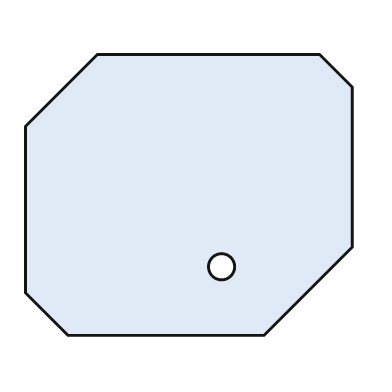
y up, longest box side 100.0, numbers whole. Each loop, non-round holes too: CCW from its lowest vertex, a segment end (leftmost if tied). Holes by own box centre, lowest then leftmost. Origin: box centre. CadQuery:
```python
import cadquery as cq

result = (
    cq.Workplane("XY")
    .moveTo(-37.0, -43.0)
    .lineTo(23.0, -43.0)
    .lineTo(50.0, -16.0)
    .lineTo(50.0, 33.0)
    .lineTo(40.0, 43.0)
    .lineTo(-28.0, 43.0)
    .lineTo(-50.0, 21.0)
    .lineTo(-50.0, -30.0)
    .close()
    .moveTo(10.0, -22.0)
    .circle(4.0)
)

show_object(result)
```